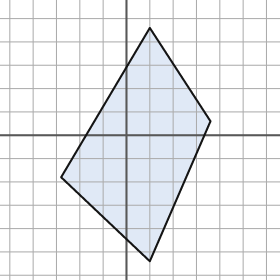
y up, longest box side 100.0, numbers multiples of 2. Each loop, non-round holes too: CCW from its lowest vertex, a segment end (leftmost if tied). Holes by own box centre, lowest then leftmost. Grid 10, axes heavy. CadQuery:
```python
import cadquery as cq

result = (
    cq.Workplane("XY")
    .moveTo(10.0, -54.0)
    .lineTo(36.0, 6.0)
    .lineTo(10.0, 46.0)
    .lineTo(-28.0, -18.0)
    .close()
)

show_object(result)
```